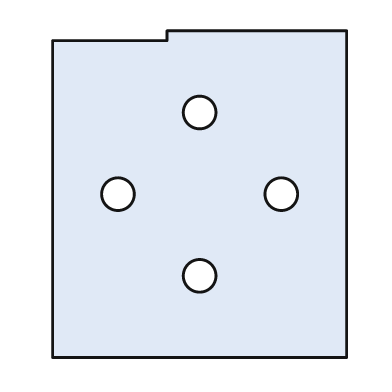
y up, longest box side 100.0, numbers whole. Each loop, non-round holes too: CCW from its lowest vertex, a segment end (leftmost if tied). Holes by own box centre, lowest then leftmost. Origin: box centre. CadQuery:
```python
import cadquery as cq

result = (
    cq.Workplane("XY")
    .moveTo(-45.0, -50.0)
    .lineTo(45.0, -50.0)
    .lineTo(45.0, 50.0)
    .lineTo(-10.0, 50.0)
    .lineTo(-10.0, 47.0)
    .lineTo(-45.0, 47.0)
    .close()
    .moveTo(0.0, -25.0)
    .circle(5.0)
    .moveTo(-25.0, 0.0)
    .circle(5.0)
    .moveTo(25.0, 0.0)
    .circle(5.0)
    .moveTo(0.0, 25.0)
    .circle(5.0)
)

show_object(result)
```